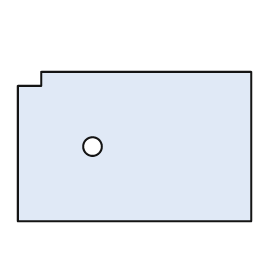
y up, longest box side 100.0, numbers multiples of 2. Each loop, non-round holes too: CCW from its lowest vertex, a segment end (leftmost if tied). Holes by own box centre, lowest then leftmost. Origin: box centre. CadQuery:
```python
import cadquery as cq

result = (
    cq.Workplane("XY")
    .moveTo(-50.0, -32.0)
    .lineTo(50.0, -32.0)
    .lineTo(50.0, 32.0)
    .lineTo(-40.0, 32.0)
    .lineTo(-40.0, 26.0)
    .lineTo(-50.0, 26.0)
    .close()
    .moveTo(-18.0, 0.0)
    .circle(4.0)
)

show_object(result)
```